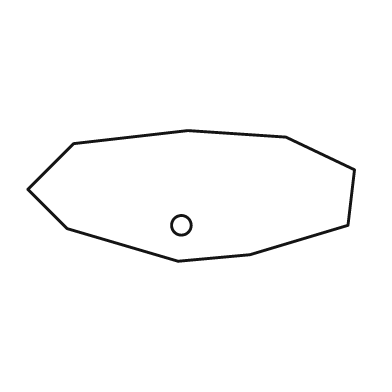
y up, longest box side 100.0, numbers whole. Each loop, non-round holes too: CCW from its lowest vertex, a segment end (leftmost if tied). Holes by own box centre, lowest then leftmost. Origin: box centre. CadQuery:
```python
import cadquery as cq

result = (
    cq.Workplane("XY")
    .moveTo(-4.0, -20.0)
    .lineTo(18.0, -18.0)
    .lineTo(48.0, -9.0)
    .lineTo(50.0, 8.0)
    .lineTo(29.0, 18.0)
    .lineTo(-1.0, 20.0)
    .lineTo(-36.0, 16.0)
    .lineTo(-50.0, 2.0)
    .lineTo(-38.0, -10.0)
    .close()
    .moveTo(-3.0, -9.0)
    .circle(3.0)
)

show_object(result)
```